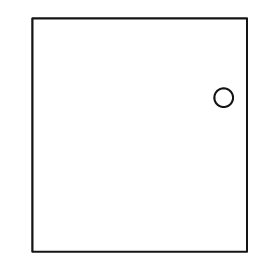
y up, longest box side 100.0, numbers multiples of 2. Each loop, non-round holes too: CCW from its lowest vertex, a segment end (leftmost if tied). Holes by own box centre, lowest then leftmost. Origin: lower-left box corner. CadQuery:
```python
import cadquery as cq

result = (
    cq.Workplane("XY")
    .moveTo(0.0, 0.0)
    .lineTo(92.0, 0.0)
    .lineTo(92.0, 100.0)
    .lineTo(0.0, 100.0)
    .close()
    .moveTo(82.0, 66.0)
    .circle(4.0)
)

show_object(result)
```